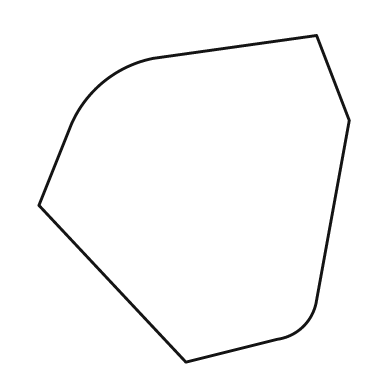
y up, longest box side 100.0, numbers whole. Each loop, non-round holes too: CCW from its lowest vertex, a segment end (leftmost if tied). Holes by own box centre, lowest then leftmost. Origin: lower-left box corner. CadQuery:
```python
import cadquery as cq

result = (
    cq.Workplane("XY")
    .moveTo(45.0, 0.0)
    .lineTo(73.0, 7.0)
    .threePointArc((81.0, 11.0), (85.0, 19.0))
    .lineTo(95.0, 74.0)
    .lineTo(85.0, 100.0)
    .lineTo(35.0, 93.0)
    .threePointArc((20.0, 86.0), (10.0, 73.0))
    .lineTo(0.0, 48.0)
    .close()
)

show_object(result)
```